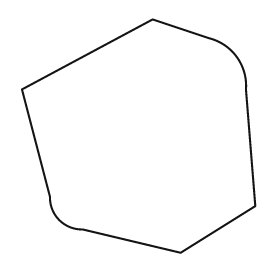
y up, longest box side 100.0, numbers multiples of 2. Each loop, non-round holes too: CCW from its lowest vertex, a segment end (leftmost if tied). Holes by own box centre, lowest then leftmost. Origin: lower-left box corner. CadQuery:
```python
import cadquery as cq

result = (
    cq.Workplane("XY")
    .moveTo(68.0, 0.0)
    .lineTo(100.0, 20.0)
    .lineTo(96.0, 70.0)
    .threePointArc((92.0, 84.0), (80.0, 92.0))
    .lineTo(56.0, 100.0)
    .lineTo(0.0, 70.0)
    .lineTo(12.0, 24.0)
    .threePointArc((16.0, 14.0), (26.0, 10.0))
    .close()
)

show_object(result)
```